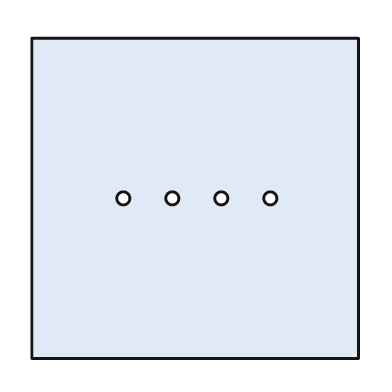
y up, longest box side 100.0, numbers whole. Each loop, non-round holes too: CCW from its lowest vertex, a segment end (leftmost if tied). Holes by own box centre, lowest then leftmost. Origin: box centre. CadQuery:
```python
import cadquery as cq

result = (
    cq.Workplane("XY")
    .moveTo(-50.0, -49.0)
    .lineTo(50.0, -49.0)
    .lineTo(50.0, 49.0)
    .lineTo(-50.0, 49.0)
    .close()
    .moveTo(-22.0, 0.0)
    .circle(2.0)
    .moveTo(-7.0, 0.0)
    .circle(2.0)
    .moveTo(8.0, 0.0)
    .circle(2.0)
    .moveTo(23.0, 0.0)
    .circle(2.0)
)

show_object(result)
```